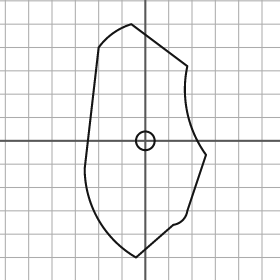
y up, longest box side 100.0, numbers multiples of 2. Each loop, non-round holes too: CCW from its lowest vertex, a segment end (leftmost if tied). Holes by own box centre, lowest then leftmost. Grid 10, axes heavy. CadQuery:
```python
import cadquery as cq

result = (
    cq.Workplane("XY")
    .moveTo(-4.0, -50.0)
    .lineTo(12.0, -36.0)
    .threePointArc((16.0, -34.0), (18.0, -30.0))
    .lineTo(26.0, -6.0)
    .threePointArc((18.0, 12.0), (18.0, 32.0))
    .lineTo(-6.0, 50.0)
    .threePointArc((-14.0, 46.0), (-20.0, 40.0))
    .lineTo(-26.0, -12.0)
    .threePointArc((-20.0, -34.0), (-4.0, -50.0))
    .close()
    .moveTo(0.0, 0.0)
    .circle(4.0)
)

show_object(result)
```